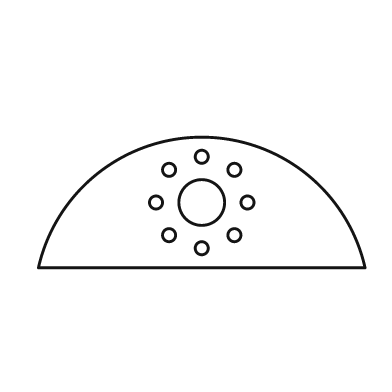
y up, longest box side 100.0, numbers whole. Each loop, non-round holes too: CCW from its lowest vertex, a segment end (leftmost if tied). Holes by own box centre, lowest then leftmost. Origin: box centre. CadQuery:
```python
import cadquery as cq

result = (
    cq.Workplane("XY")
    .moveTo(-50.0, -20.0)
    .lineTo(50.0, -20.0)
    .threePointArc((0.0, 20.0), (-50.0, -20.0))
    .close()
    .moveTo(0.0, -14.0)
    .circle(2.0)
    .moveTo(-10.0, -10.0)
    .circle(2.0)
    .moveTo(10.0, -10.0)
    .circle(2.0)
    .moveTo(-14.0, 0.0)
    .circle(2.0)
    .moveTo(0.0, 0.0)
    .circle(7.0)
    .moveTo(14.0, 0.0)
    .circle(2.0)
    .moveTo(-10.0, 10.0)
    .circle(2.0)
    .moveTo(10.0, 10.0)
    .circle(2.0)
    .moveTo(0.0, 14.0)
    .circle(2.0)
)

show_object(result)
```